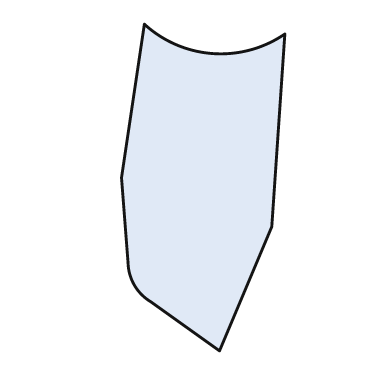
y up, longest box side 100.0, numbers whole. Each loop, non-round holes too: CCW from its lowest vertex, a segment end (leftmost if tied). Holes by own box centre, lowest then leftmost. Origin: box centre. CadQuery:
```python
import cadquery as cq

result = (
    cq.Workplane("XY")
    .moveTo(5.0, -50.0)
    .lineTo(21.0, -12.0)
    .lineTo(25.0, 47.0)
    .threePointArc((3.0, 41.0), (-18.0, 50.0))
    .lineTo(-25.0, 3.0)
    .lineTo(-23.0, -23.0)
    .threePointArc((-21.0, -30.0), (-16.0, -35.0))
    .close()
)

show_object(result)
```